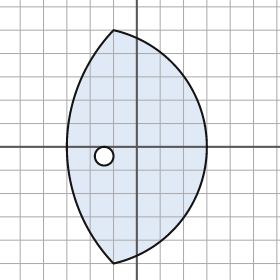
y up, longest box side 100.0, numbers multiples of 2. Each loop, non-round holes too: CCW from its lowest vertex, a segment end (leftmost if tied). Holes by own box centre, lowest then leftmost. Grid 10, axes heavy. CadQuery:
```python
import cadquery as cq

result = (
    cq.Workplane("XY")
    .moveTo(-10.0, -50.0)
    .threePointArc((30.0, 0.0), (-10.0, 50.0))
    .threePointArc((-30.0, 0.0), (-10.0, -50.0))
    .close()
    .moveTo(-14.0, -4.0)
    .circle(4.0)
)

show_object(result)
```